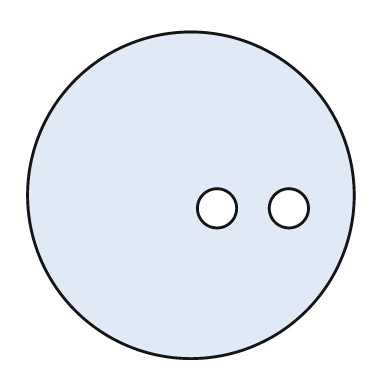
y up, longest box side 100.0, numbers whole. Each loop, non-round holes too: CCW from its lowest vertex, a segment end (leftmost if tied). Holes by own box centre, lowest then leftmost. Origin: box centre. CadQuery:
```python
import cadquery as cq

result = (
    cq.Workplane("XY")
    .moveTo(0.0, 0.0)
    .circle(50.0)
    .moveTo(8.0, -4.0)
    .circle(6.0)
    .moveTo(30.0, -4.0)
    .circle(6.0)
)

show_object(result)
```